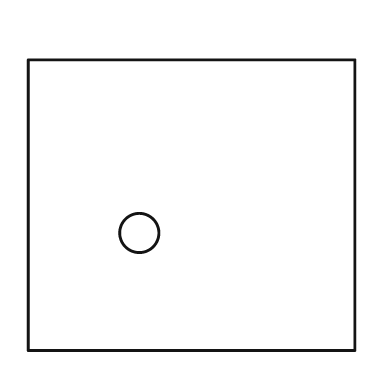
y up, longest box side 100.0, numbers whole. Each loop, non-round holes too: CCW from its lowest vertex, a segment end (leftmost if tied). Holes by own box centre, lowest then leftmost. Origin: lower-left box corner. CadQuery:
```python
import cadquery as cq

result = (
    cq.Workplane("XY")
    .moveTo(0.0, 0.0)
    .lineTo(100.0, 0.0)
    .lineTo(100.0, 89.0)
    .lineTo(0.0, 89.0)
    .close()
    .moveTo(34.0, 36.0)
    .circle(6.0)
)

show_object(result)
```